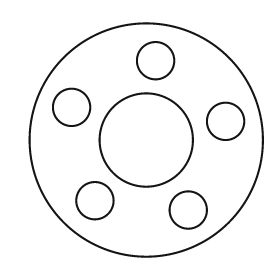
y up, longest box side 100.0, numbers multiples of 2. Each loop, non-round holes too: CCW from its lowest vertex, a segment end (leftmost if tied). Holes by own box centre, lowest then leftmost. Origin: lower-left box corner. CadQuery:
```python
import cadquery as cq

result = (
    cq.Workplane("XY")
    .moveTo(50.0, 50.0)
    .circle(50.0)
    .moveTo(68.0, 20.0)
    .circle(8.0)
    .moveTo(28.0, 24.0)
    .circle(8.0)
    .moveTo(50.0, 50.0)
    .circle(20.0)
    .moveTo(84.0, 58.0)
    .circle(8.0)
    .moveTo(18.0, 64.0)
    .circle(8.0)
    .moveTo(54.0, 84.0)
    .circle(8.0)
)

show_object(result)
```